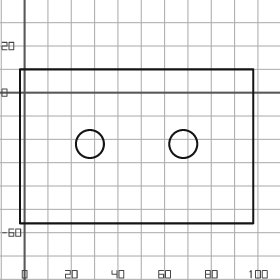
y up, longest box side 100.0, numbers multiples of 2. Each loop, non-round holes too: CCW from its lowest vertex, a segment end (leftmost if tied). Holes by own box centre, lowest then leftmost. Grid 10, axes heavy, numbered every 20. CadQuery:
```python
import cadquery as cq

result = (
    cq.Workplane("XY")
    .moveTo(-2.0, -56.0)
    .lineTo(98.0, -56.0)
    .lineTo(98.0, 10.0)
    .lineTo(-2.0, 10.0)
    .close()
    .moveTo(28.0, -22.0)
    .circle(6.0)
    .moveTo(68.0, -22.0)
    .circle(6.0)
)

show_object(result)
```